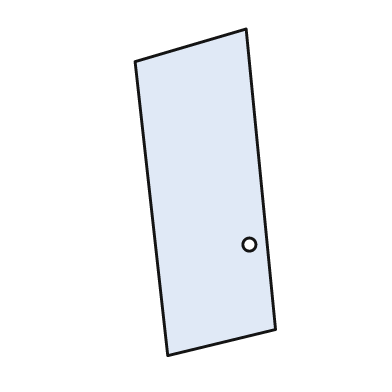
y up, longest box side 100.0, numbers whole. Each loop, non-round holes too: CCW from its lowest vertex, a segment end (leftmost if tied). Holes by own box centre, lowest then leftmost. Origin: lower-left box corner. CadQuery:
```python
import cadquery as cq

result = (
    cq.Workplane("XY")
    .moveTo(10.0, 0.0)
    .lineTo(43.0, 8.0)
    .lineTo(34.0, 100.0)
    .lineTo(0.0, 90.0)
    .close()
    .moveTo(35.0, 34.0)
    .circle(2.0)
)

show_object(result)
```